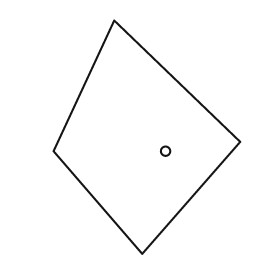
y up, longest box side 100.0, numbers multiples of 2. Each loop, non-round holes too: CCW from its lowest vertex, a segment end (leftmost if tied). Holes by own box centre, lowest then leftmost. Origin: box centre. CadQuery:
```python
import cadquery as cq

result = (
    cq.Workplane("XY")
    .moveTo(-2.0, -50.0)
    .lineTo(40.0, -2.0)
    .lineTo(-14.0, 50.0)
    .lineTo(-40.0, -6.0)
    .close()
    .moveTo(8.0, -6.0)
    .circle(2.0)
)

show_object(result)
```